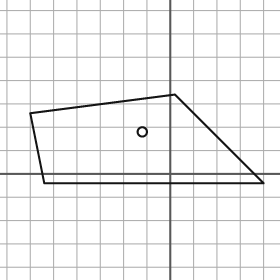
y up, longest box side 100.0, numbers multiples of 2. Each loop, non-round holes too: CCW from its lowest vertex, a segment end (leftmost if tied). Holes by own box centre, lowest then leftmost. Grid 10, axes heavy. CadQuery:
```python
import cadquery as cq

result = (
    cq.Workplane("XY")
    .moveTo(-54.0, -4.0)
    .lineTo(40.0, -4.0)
    .lineTo(2.0, 34.0)
    .lineTo(-60.0, 26.0)
    .close()
    .moveTo(-12.0, 18.0)
    .circle(2.0)
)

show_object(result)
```